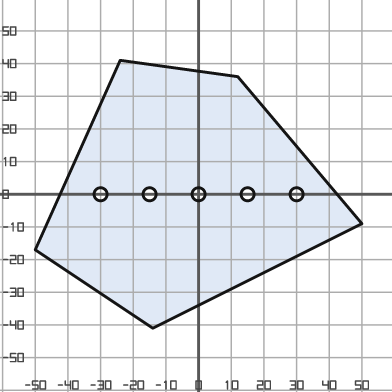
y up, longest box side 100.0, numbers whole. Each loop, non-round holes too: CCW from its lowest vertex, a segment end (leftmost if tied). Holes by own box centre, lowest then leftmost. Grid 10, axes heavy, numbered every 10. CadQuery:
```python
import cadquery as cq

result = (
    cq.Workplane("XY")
    .moveTo(-14.0, -41.0)
    .lineTo(50.0, -9.0)
    .lineTo(12.0, 36.0)
    .lineTo(-24.0, 41.0)
    .lineTo(-50.0, -17.0)
    .close()
    .moveTo(-30.0, 0.0)
    .circle(2.0)
    .moveTo(-15.0, 0.0)
    .circle(2.0)
    .moveTo(0.0, 0.0)
    .circle(2.0)
    .moveTo(15.0, 0.0)
    .circle(2.0)
    .moveTo(30.0, 0.0)
    .circle(2.0)
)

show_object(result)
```